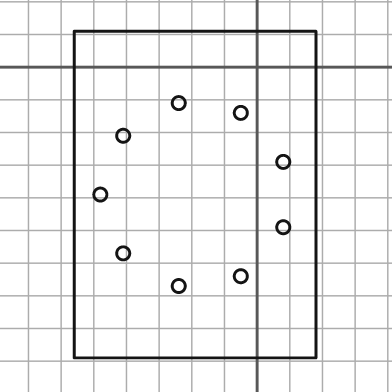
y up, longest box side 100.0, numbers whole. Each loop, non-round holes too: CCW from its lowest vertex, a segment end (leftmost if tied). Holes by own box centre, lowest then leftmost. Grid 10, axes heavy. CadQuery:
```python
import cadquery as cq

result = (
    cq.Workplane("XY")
    .moveTo(-56.0, -89.0)
    .lineTo(18.0, -89.0)
    .lineTo(18.0, 11.0)
    .lineTo(-56.0, 11.0)
    .close()
    .moveTo(-24.0, -67.0)
    .circle(2.0)
    .moveTo(-5.0, -64.0)
    .circle(2.0)
    .moveTo(-41.0, -57.0)
    .circle(2.0)
    .moveTo(8.0, -49.0)
    .circle(2.0)
    .moveTo(-48.0, -39.0)
    .circle(2.0)
    .moveTo(8.0, -29.0)
    .circle(2.0)
    .moveTo(-41.0, -21.0)
    .circle(2.0)
    .moveTo(-5.0, -14.0)
    .circle(2.0)
    .moveTo(-24.0, -11.0)
    .circle(2.0)
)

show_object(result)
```